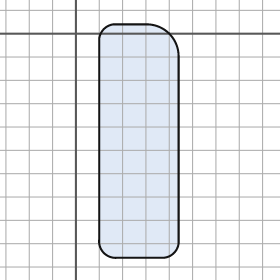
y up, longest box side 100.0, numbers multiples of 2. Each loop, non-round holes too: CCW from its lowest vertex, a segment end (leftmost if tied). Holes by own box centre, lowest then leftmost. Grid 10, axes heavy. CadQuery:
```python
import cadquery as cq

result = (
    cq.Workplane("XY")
    .moveTo(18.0, -96.0)
    .lineTo(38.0, -96.0)
    .threePointArc((42.0, -94.0), (44.0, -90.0))
    .lineTo(44.0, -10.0)
    .threePointArc((40.0, 0.0), (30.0, 4.0))
    .lineTo(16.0, 4.0)
    .threePointArc((12.0, 2.0), (10.0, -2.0))
    .lineTo(10.0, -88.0)
    .threePointArc((12.0, -94.0), (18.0, -96.0))
    .close()
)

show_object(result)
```